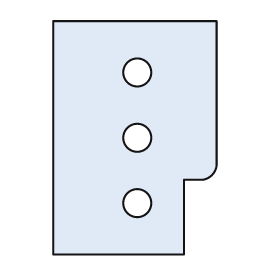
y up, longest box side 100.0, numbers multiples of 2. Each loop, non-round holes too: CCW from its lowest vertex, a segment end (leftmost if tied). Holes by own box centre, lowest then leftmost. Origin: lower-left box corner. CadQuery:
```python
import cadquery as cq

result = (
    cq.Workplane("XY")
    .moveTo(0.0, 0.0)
    .lineTo(56.0, 0.0)
    .lineTo(56.0, 32.0)
    .lineTo(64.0, 32.0)
    .threePointArc((68.0, 34.0), (70.0, 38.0))
    .lineTo(70.0, 100.0)
    .lineTo(0.0, 100.0)
    .close()
    .moveTo(36.0, 22.0)
    .circle(6.0)
    .moveTo(36.0, 50.0)
    .circle(6.0)
    .moveTo(36.0, 78.0)
    .circle(6.0)
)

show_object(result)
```